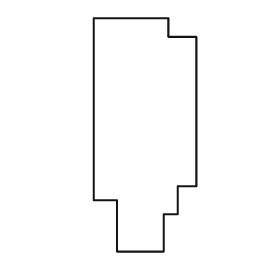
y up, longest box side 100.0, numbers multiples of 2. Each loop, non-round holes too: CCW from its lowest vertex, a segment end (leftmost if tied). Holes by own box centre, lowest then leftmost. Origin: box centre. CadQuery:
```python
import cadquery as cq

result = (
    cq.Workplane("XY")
    .moveTo(-12.0, -50.0)
    .lineTo(8.0, -50.0)
    .lineTo(8.0, -34.0)
    .lineTo(14.0, -34.0)
    .lineTo(14.0, -22.0)
    .lineTo(22.0, -22.0)
    .lineTo(22.0, 42.0)
    .lineTo(10.0, 42.0)
    .lineTo(10.0, 50.0)
    .lineTo(-22.0, 50.0)
    .lineTo(-22.0, -28.0)
    .lineTo(-12.0, -28.0)
    .close()
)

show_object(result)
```